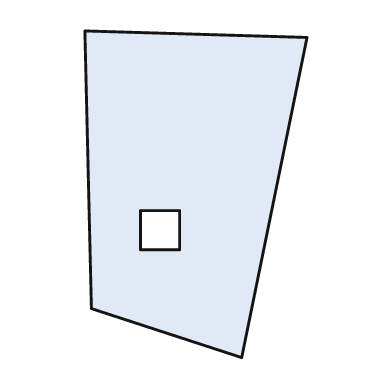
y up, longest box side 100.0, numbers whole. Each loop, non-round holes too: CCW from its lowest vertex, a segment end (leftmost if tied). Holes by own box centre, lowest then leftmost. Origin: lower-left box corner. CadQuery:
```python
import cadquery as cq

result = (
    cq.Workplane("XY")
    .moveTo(48.0, 0.0)
    .lineTo(68.0, 98.0)
    .lineTo(0.0, 100.0)
    .lineTo(2.0, 15.0)
    .close()
    .moveTo(17.0, 33.0)
    .lineTo(29.0, 33.0)
    .lineTo(29.0, 45.0)
    .lineTo(17.0, 45.0)
    .close()
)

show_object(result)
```